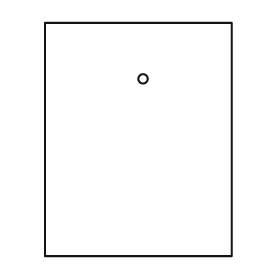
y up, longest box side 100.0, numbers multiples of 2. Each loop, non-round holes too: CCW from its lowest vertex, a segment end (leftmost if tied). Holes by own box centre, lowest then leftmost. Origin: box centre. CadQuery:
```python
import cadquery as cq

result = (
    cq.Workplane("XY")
    .moveTo(-40.0, -50.0)
    .lineTo(40.0, -50.0)
    .lineTo(40.0, 50.0)
    .lineTo(-40.0, 50.0)
    .close()
    .moveTo(2.0, 26.0)
    .circle(2.0)
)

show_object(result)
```